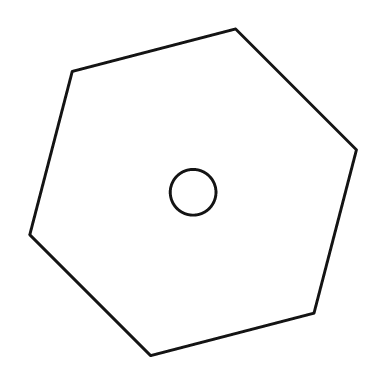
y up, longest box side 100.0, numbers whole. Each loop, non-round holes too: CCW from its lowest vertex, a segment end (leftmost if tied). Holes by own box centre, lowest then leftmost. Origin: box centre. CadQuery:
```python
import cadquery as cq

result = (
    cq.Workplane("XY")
    .moveTo(-13.0, -50.0)
    .lineTo(37.0, -37.0)
    .lineTo(50.0, 13.0)
    .lineTo(13.0, 50.0)
    .lineTo(-37.0, 37.0)
    .lineTo(-50.0, -13.0)
    .close()
    .moveTo(0.0, 0.0)
    .circle(7.0)
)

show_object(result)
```